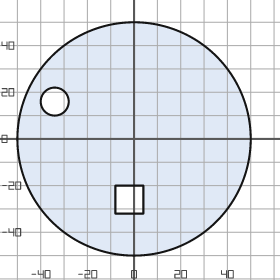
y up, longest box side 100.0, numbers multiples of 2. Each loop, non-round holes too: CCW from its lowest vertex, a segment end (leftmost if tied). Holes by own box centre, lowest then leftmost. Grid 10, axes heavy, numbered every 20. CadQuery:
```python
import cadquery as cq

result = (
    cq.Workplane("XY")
    .moveTo(0.0, 0.0)
    .circle(50.0)
    .moveTo(-8.0, -32.0)
    .lineTo(4.0, -32.0)
    .lineTo(4.0, -20.0)
    .lineTo(-8.0, -20.0)
    .close()
    .moveTo(-34.0, 16.0)
    .circle(6.0)
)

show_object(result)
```